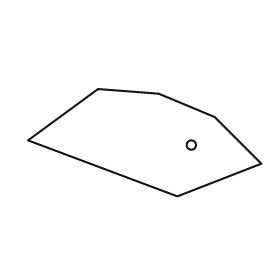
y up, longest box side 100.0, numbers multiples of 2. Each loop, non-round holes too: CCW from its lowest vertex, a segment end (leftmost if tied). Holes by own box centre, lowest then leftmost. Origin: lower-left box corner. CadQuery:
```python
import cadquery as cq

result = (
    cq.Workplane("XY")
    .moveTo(64.0, 0.0)
    .lineTo(100.0, 14.0)
    .lineTo(80.0, 34.0)
    .lineTo(56.0, 44.0)
    .lineTo(30.0, 46.0)
    .lineTo(0.0, 24.0)
    .close()
    .moveTo(70.0, 22.0)
    .circle(2.0)
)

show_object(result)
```